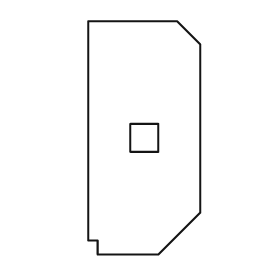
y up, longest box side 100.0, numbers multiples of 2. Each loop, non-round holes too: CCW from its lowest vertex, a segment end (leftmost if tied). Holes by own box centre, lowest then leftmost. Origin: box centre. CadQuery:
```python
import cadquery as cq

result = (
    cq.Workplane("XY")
    .moveTo(-20.0, -50.0)
    .lineTo(6.0, -50.0)
    .lineTo(24.0, -32.0)
    .lineTo(24.0, 40.0)
    .lineTo(14.0, 50.0)
    .lineTo(-24.0, 50.0)
    .lineTo(-24.0, -44.0)
    .lineTo(-20.0, -44.0)
    .close()
    .moveTo(-6.0, -6.0)
    .lineTo(6.0, -6.0)
    .lineTo(6.0, 6.0)
    .lineTo(-6.0, 6.0)
    .close()
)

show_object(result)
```